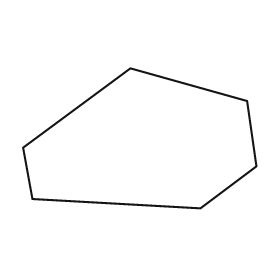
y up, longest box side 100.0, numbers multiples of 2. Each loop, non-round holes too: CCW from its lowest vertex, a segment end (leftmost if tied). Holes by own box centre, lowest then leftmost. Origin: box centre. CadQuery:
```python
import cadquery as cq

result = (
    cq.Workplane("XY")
    .moveTo(26.0, -30.0)
    .lineTo(50.0, -12.0)
    .lineTo(46.0, 16.0)
    .lineTo(-4.0, 30.0)
    .lineTo(-50.0, -4.0)
    .lineTo(-46.0, -26.0)
    .close()
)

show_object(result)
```